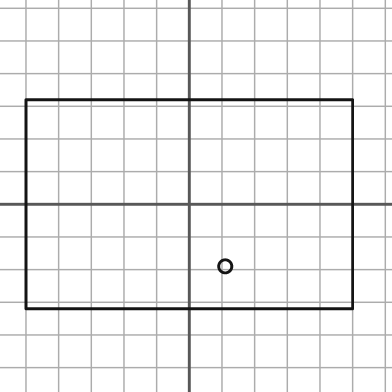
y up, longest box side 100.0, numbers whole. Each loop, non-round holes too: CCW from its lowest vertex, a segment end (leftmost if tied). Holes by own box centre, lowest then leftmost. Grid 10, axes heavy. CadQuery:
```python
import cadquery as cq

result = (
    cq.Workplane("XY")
    .moveTo(-50.0, -32.0)
    .lineTo(50.0, -32.0)
    .lineTo(50.0, 32.0)
    .lineTo(-50.0, 32.0)
    .close()
    .moveTo(11.0, -19.0)
    .circle(2.0)
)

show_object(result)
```